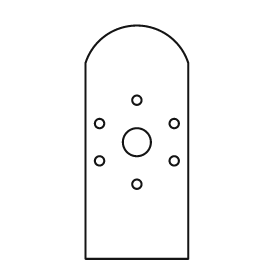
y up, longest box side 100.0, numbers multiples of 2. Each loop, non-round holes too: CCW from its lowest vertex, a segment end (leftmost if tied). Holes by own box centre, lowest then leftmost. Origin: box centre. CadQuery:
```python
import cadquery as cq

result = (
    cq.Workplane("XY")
    .moveTo(-22.0, -50.0)
    .lineTo(22.0, -50.0)
    .lineTo(22.0, 34.0)
    .threePointArc((0.0, 50.0), (-22.0, 34.0))
    .close()
    .moveTo(0.0, -18.0)
    .circle(2.0)
    .moveTo(-16.0, -8.0)
    .circle(2.0)
    .moveTo(16.0, -8.0)
    .circle(2.0)
    .moveTo(0.0, 0.0)
    .circle(6.0)
    .moveTo(-16.0, 8.0)
    .circle(2.0)
    .moveTo(16.0, 8.0)
    .circle(2.0)
    .moveTo(0.0, 18.0)
    .circle(2.0)
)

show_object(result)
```